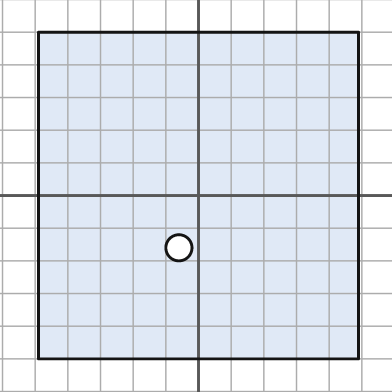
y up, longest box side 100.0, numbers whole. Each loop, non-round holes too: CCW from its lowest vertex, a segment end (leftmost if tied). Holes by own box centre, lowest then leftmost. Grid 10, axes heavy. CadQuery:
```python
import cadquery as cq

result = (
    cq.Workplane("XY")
    .moveTo(-49.0, -50.0)
    .lineTo(49.0, -50.0)
    .lineTo(49.0, 50.0)
    .lineTo(-49.0, 50.0)
    .close()
    .moveTo(-6.0, -16.0)
    .circle(4.0)
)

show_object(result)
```